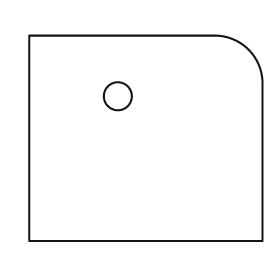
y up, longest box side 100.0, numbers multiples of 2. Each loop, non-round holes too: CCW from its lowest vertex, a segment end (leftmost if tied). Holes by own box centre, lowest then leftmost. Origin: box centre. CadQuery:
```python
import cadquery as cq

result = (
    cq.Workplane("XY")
    .moveTo(-50.0, -44.0)
    .lineTo(50.0, -44.0)
    .lineTo(50.0, 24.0)
    .threePointArc((44.0, 38.0), (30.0, 44.0))
    .lineTo(-50.0, 44.0)
    .close()
    .moveTo(-12.0, 18.0)
    .circle(6.0)
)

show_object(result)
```